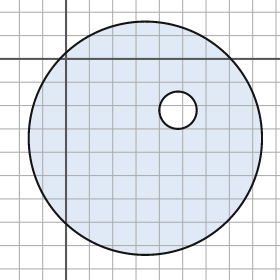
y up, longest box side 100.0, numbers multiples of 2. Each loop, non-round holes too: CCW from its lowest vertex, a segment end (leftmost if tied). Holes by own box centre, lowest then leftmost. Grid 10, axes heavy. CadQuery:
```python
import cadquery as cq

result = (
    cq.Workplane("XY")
    .moveTo(34.0, -34.0)
    .circle(50.0)
    .moveTo(48.0, -22.0)
    .circle(8.0)
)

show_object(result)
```